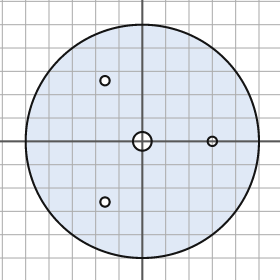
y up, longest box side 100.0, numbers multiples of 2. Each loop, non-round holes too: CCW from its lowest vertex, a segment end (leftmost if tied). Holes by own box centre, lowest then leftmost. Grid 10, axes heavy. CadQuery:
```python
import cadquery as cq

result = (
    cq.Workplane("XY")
    .moveTo(0.0, 0.0)
    .circle(50.0)
    .moveTo(-16.0, -26.0)
    .circle(2.0)
    .moveTo(0.0, 0.0)
    .circle(4.0)
    .moveTo(30.0, 0.0)
    .circle(2.0)
    .moveTo(-16.0, 26.0)
    .circle(2.0)
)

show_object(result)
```